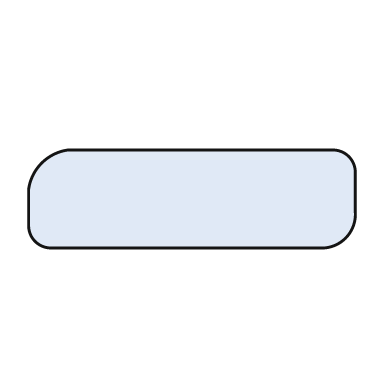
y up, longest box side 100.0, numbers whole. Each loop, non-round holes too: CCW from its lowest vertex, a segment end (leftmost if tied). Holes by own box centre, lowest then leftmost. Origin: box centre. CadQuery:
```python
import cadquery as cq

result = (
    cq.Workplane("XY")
    .moveTo(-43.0, -15.0)
    .lineTo(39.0, -15.0)
    .threePointArc((47.0, -12.0), (50.0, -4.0))
    .lineTo(50.0, 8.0)
    .threePointArc((48.0, 13.0), (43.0, 15.0))
    .lineTo(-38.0, 15.0)
    .threePointArc((-46.0, 11.0), (-50.0, 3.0))
    .lineTo(-50.0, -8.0)
    .threePointArc((-48.0, -13.0), (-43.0, -15.0))
    .close()
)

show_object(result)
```